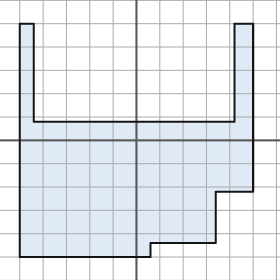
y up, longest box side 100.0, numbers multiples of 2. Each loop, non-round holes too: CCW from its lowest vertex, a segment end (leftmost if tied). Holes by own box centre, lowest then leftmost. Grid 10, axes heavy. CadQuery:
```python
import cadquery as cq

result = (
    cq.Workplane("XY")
    .moveTo(-50.0, -50.0)
    .lineTo(6.0, -50.0)
    .lineTo(6.0, -44.0)
    .lineTo(34.0, -44.0)
    .lineTo(34.0, -22.0)
    .lineTo(50.0, -22.0)
    .lineTo(50.0, 50.0)
    .lineTo(42.0, 50.0)
    .lineTo(42.0, 8.0)
    .lineTo(-44.0, 8.0)
    .lineTo(-44.0, 50.0)
    .lineTo(-50.0, 50.0)
    .close()
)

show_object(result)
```